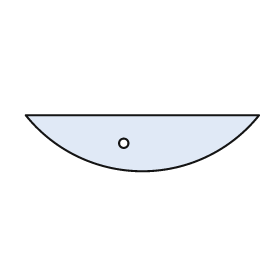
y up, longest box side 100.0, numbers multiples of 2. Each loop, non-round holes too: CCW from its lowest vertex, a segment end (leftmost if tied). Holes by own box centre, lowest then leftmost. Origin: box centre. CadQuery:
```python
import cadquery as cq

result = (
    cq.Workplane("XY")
    .moveTo(-50.0, 12.0)
    .threePointArc((0.0, -12.0), (50.0, 12.0))
    .close()
    .moveTo(-8.0, 0.0)
    .circle(2.0)
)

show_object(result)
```